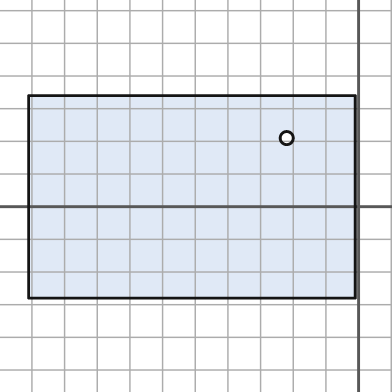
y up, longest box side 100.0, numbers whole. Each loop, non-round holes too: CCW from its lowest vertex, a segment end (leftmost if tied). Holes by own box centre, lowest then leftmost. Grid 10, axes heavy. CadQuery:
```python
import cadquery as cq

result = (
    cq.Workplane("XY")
    .moveTo(-101.0, -28.0)
    .lineTo(-1.0, -28.0)
    .lineTo(-1.0, 34.0)
    .lineTo(-101.0, 34.0)
    .close()
    .moveTo(-22.0, 21.0)
    .circle(2.0)
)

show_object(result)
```